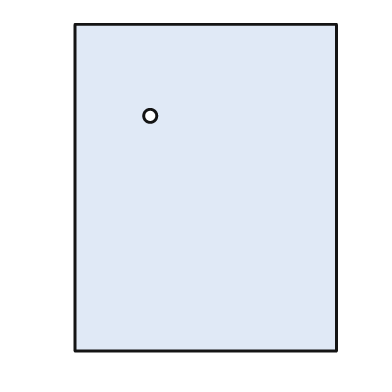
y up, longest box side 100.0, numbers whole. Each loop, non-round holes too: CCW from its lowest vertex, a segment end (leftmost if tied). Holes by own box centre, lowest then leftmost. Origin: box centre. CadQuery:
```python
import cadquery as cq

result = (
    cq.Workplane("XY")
    .moveTo(-40.0, -50.0)
    .lineTo(40.0, -50.0)
    .lineTo(40.0, 50.0)
    .lineTo(-40.0, 50.0)
    .close()
    .moveTo(-17.0, 22.0)
    .circle(2.0)
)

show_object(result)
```